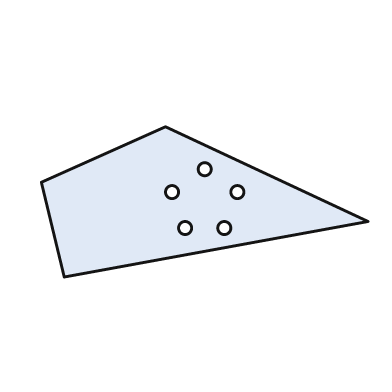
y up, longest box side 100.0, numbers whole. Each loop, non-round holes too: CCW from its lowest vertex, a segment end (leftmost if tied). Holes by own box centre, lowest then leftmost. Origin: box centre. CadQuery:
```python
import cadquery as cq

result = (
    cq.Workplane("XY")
    .moveTo(-43.0, -23.0)
    .lineTo(50.0, -6.0)
    .lineTo(-12.0, 23.0)
    .lineTo(-50.0, 6.0)
    .close()
    .moveTo(-6.0, -8.0)
    .circle(2.0)
    .moveTo(6.0, -8.0)
    .circle(2.0)
    .moveTo(-10.0, 3.0)
    .circle(2.0)
    .moveTo(10.0, 3.0)
    .circle(2.0)
    .moveTo(0.0, 10.0)
    .circle(2.0)
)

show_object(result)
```